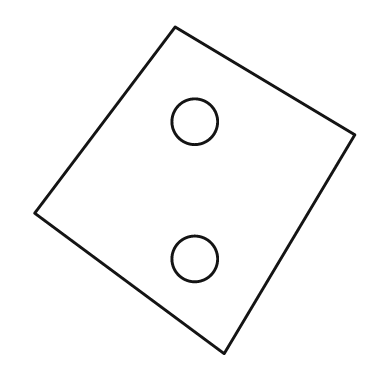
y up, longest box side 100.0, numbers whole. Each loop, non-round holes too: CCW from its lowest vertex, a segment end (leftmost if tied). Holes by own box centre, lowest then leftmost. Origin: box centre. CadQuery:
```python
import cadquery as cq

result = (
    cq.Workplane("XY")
    .moveTo(9.0, -50.0)
    .lineTo(49.0, 17.0)
    .lineTo(-6.0, 50.0)
    .lineTo(-49.0, -7.0)
    .close()
    .moveTo(0.0, -21.0)
    .circle(7.0)
    .moveTo(0.0, 21.0)
    .circle(7.0)
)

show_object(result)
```